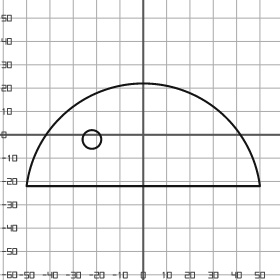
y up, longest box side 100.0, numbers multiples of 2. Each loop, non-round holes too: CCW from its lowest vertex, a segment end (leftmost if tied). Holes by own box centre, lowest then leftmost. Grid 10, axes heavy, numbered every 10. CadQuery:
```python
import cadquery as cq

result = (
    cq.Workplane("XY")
    .moveTo(-50.0, -22.0)
    .lineTo(50.0, -22.0)
    .threePointArc((0.0, 22.0), (-50.0, -22.0))
    .close()
    .moveTo(-22.0, -2.0)
    .circle(4.0)
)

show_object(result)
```